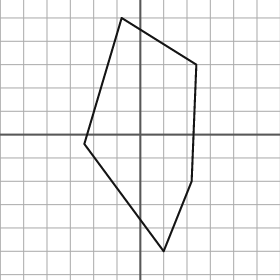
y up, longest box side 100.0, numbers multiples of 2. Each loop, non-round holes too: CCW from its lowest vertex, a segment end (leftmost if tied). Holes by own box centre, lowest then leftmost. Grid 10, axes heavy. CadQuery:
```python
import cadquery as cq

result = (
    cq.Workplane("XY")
    .moveTo(10.0, -50.0)
    .lineTo(22.0, -20.0)
    .lineTo(24.0, 30.0)
    .lineTo(-8.0, 50.0)
    .lineTo(-24.0, -4.0)
    .close()
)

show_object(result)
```